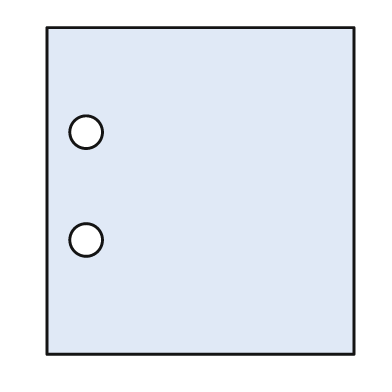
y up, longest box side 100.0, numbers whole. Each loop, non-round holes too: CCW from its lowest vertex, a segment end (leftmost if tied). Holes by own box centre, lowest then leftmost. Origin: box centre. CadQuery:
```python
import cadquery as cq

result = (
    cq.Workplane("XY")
    .moveTo(-47.0, -50.0)
    .lineTo(47.0, -50.0)
    .lineTo(47.0, 50.0)
    .lineTo(-47.0, 50.0)
    .close()
    .moveTo(-35.0, -15.0)
    .circle(5.0)
    .moveTo(-35.0, 18.0)
    .circle(5.0)
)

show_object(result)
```